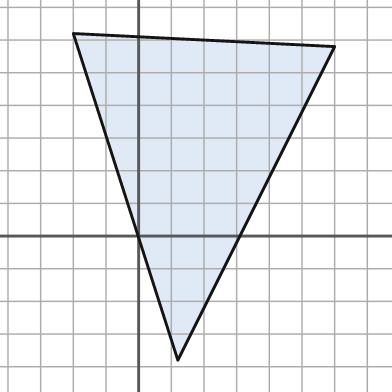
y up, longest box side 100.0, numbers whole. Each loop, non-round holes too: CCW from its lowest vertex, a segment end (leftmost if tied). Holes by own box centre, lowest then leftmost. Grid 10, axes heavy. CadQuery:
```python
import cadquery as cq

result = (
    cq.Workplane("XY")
    .moveTo(12.0, -38.0)
    .lineTo(60.0, 58.0)
    .lineTo(-20.0, 62.0)
    .close()
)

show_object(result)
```